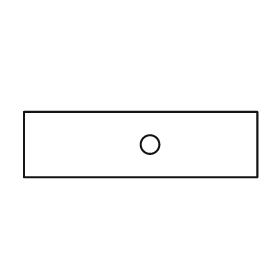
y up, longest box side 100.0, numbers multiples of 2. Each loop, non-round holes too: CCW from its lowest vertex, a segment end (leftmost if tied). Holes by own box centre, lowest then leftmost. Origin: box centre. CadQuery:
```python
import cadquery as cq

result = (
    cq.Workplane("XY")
    .moveTo(-50.0, -14.0)
    .lineTo(50.0, -14.0)
    .lineTo(50.0, 14.0)
    .lineTo(-50.0, 14.0)
    .close()
    .moveTo(4.0, 0.0)
    .circle(4.0)
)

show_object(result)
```